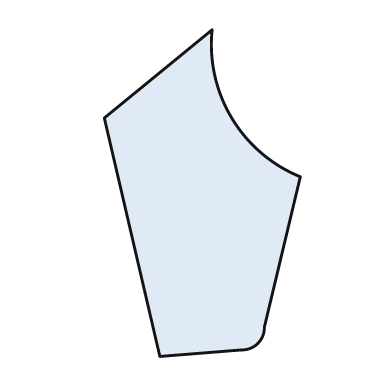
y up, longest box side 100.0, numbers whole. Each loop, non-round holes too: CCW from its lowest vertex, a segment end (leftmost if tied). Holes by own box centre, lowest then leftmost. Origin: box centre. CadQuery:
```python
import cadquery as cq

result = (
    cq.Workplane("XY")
    .moveTo(-13.0, -50.0)
    .lineTo(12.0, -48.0)
    .threePointArc((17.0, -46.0), (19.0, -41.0))
    .lineTo(30.0, 5.0)
    .threePointArc((9.0, 23.0), (3.0, 50.0))
    .lineTo(-30.0, 23.0)
    .close()
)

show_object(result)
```